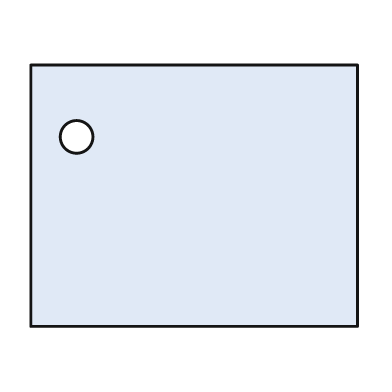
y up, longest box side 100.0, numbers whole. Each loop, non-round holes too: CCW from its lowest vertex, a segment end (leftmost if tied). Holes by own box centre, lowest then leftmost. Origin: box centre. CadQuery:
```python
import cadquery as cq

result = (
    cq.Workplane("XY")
    .moveTo(-50.0, -40.0)
    .lineTo(50.0, -40.0)
    .lineTo(50.0, 40.0)
    .lineTo(-50.0, 40.0)
    .close()
    .moveTo(-36.0, 18.0)
    .circle(5.0)
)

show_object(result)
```